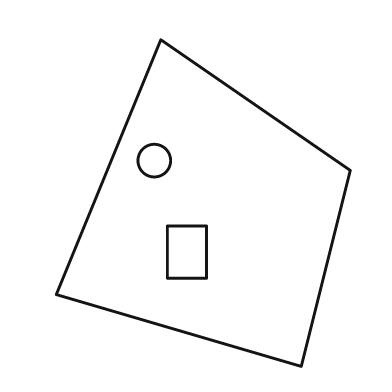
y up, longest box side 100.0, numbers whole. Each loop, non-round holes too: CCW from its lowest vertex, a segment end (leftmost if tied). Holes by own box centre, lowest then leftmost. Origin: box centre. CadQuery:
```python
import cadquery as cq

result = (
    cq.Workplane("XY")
    .moveTo(30.0, -50.0)
    .lineTo(45.0, 10.0)
    .lineTo(-13.0, 50.0)
    .lineTo(-45.0, -28.0)
    .close()
    .moveTo(-11.0, -23.0)
    .lineTo(1.0, -23.0)
    .lineTo(1.0, -7.0)
    .lineTo(-11.0, -7.0)
    .close()
    .moveTo(-15.0, 13.0)
    .circle(5.0)
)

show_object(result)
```